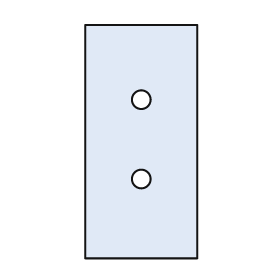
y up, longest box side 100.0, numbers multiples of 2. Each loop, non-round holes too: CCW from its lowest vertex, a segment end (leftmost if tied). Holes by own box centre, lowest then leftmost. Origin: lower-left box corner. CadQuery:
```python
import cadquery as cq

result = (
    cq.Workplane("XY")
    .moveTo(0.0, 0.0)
    .lineTo(48.0, 0.0)
    .lineTo(48.0, 100.0)
    .lineTo(0.0, 100.0)
    .close()
    .moveTo(24.0, 34.0)
    .circle(4.0)
    .moveTo(24.0, 68.0)
    .circle(4.0)
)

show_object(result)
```